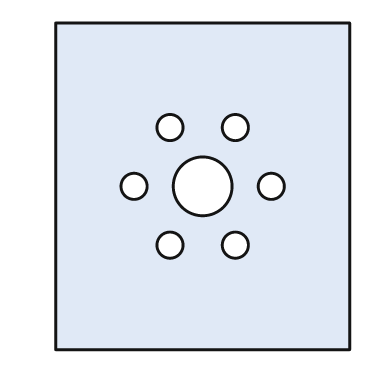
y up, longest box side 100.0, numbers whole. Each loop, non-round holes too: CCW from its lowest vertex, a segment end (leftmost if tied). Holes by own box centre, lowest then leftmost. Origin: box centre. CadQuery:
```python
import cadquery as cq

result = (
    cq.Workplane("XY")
    .moveTo(-45.0, -50.0)
    .lineTo(45.0, -50.0)
    .lineTo(45.0, 50.0)
    .lineTo(-45.0, 50.0)
    .close()
    .moveTo(-10.0, -18.0)
    .circle(4.0)
    .moveTo(10.0, -18.0)
    .circle(4.0)
    .moveTo(-21.0, 0.0)
    .circle(4.0)
    .moveTo(0.0, 0.0)
    .circle(9.0)
    .moveTo(21.0, 0.0)
    .circle(4.0)
    .moveTo(-10.0, 18.0)
    .circle(4.0)
    .moveTo(10.0, 18.0)
    .circle(4.0)
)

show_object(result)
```